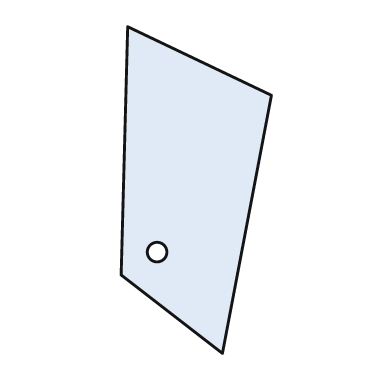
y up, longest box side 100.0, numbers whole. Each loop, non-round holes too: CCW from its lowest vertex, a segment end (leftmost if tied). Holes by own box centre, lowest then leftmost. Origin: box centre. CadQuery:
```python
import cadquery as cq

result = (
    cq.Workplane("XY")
    .moveTo(8.0, -50.0)
    .lineTo(23.0, 29.0)
    .lineTo(-21.0, 50.0)
    .lineTo(-23.0, -26.0)
    .close()
    .moveTo(-12.0, -19.0)
    .circle(3.0)
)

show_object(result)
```